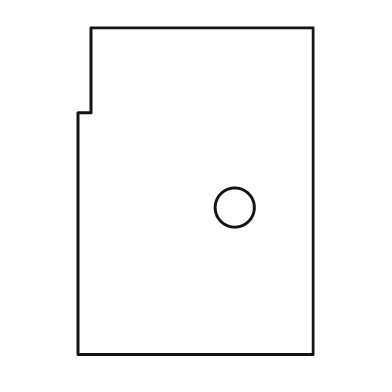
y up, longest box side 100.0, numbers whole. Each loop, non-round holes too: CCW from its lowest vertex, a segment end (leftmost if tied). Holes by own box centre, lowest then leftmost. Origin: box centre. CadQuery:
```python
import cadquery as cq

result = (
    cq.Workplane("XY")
    .moveTo(-36.0, -50.0)
    .lineTo(36.0, -50.0)
    .lineTo(36.0, 50.0)
    .lineTo(-32.0, 50.0)
    .lineTo(-32.0, 24.0)
    .lineTo(-36.0, 24.0)
    .close()
    .moveTo(12.0, -5.0)
    .circle(6.0)
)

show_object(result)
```